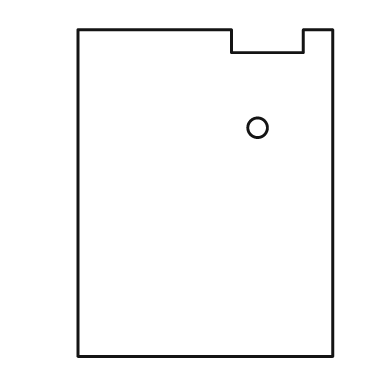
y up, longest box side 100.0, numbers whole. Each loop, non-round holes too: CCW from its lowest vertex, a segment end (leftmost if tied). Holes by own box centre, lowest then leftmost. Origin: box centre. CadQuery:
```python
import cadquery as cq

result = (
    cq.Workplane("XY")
    .moveTo(-39.0, -50.0)
    .lineTo(39.0, -50.0)
    .lineTo(39.0, 50.0)
    .lineTo(30.0, 50.0)
    .lineTo(30.0, 43.0)
    .lineTo(8.0, 43.0)
    .lineTo(8.0, 50.0)
    .lineTo(-39.0, 50.0)
    .close()
    .moveTo(16.0, 20.0)
    .circle(3.0)
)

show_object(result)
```